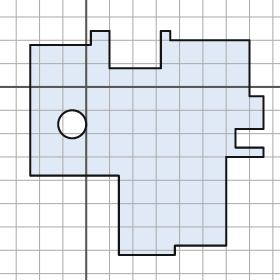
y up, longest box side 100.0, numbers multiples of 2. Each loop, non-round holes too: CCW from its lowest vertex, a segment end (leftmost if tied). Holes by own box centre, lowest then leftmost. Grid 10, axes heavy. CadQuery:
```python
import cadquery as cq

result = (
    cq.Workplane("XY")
    .moveTo(14.0, -72.0)
    .lineTo(38.0, -72.0)
    .lineTo(38.0, -68.0)
    .lineTo(60.0, -68.0)
    .lineTo(60.0, -30.0)
    .lineTo(76.0, -30.0)
    .lineTo(76.0, -26.0)
    .lineTo(64.0, -26.0)
    .lineTo(64.0, -18.0)
    .lineTo(76.0, -18.0)
    .lineTo(76.0, -4.0)
    .lineTo(70.0, -4.0)
    .lineTo(70.0, 20.0)
    .lineTo(36.0, 20.0)
    .lineTo(36.0, 24.0)
    .lineTo(32.0, 24.0)
    .lineTo(32.0, 8.0)
    .lineTo(10.0, 8.0)
    .lineTo(10.0, 24.0)
    .lineTo(2.0, 24.0)
    .lineTo(2.0, 18.0)
    .lineTo(-24.0, 18.0)
    .lineTo(-24.0, -38.0)
    .lineTo(14.0, -38.0)
    .close()
    .moveTo(-6.0, -16.0)
    .circle(6.0)
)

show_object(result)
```